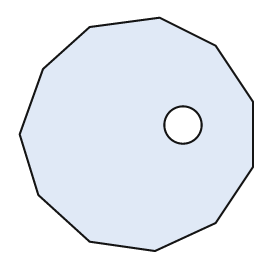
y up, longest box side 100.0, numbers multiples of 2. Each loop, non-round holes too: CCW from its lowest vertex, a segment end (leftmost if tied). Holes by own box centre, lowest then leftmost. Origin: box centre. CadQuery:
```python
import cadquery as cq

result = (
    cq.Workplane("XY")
    .moveTo(8.0, -50.0)
    .lineTo(34.0, -38.0)
    .lineTo(50.0, -14.0)
    .lineTo(50.0, 14.0)
    .lineTo(34.0, 38.0)
    .lineTo(10.0, 50.0)
    .lineTo(-20.0, 46.0)
    .lineTo(-40.0, 28.0)
    .lineTo(-50.0, 0.0)
    .lineTo(-42.0, -26.0)
    .lineTo(-20.0, -46.0)
    .close()
    .moveTo(20.0, 4.0)
    .circle(8.0)
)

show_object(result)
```